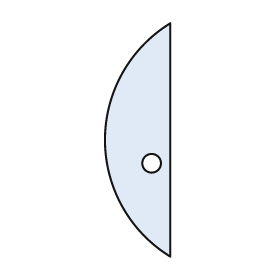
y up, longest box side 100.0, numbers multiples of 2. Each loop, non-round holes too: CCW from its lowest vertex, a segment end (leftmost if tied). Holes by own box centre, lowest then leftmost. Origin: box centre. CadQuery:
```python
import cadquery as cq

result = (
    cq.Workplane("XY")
    .moveTo(14.0, -50.0)
    .lineTo(14.0, 50.0)
    .threePointArc((-14.0, 0.0), (14.0, -50.0))
    .close()
    .moveTo(6.0, -10.0)
    .circle(4.0)
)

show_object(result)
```